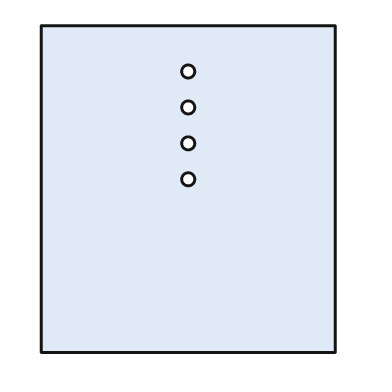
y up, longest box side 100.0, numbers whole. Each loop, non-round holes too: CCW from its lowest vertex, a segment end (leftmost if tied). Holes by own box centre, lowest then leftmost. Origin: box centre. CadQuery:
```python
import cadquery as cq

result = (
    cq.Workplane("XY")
    .moveTo(-45.0, -50.0)
    .lineTo(45.0, -50.0)
    .lineTo(45.0, 50.0)
    .lineTo(-45.0, 50.0)
    .close()
    .moveTo(0.0, 3.0)
    .circle(2.0)
    .moveTo(0.0, 14.0)
    .circle(2.0)
    .moveTo(0.0, 25.0)
    .circle(2.0)
    .moveTo(0.0, 36.0)
    .circle(2.0)
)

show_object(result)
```